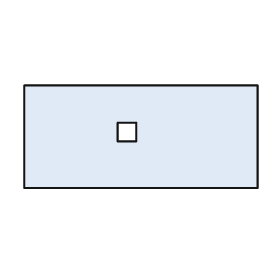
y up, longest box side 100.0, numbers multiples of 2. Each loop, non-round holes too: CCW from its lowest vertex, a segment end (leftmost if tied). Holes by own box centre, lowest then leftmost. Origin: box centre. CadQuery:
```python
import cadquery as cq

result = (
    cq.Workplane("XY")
    .moveTo(-50.0, -22.0)
    .lineTo(50.0, -22.0)
    .lineTo(50.0, 22.0)
    .lineTo(-50.0, 22.0)
    .close()
    .moveTo(-10.0, -2.0)
    .lineTo(-2.0, -2.0)
    .lineTo(-2.0, 6.0)
    .lineTo(-10.0, 6.0)
    .close()
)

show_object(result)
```